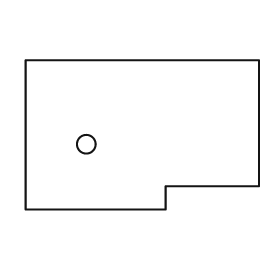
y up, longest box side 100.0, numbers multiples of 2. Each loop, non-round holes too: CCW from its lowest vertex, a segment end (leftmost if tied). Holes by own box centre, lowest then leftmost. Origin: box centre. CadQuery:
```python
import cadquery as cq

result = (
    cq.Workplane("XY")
    .moveTo(-50.0, -32.0)
    .lineTo(10.0, -32.0)
    .lineTo(10.0, -22.0)
    .lineTo(50.0, -22.0)
    .lineTo(50.0, 32.0)
    .lineTo(-50.0, 32.0)
    .close()
    .moveTo(-24.0, -4.0)
    .circle(4.0)
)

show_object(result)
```